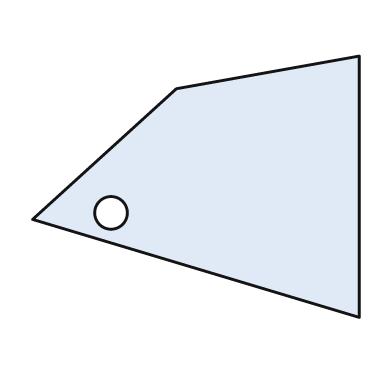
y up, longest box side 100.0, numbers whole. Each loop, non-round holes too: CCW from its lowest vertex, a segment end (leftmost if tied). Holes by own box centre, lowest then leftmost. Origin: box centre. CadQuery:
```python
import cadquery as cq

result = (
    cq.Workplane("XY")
    .moveTo(50.0, -40.0)
    .lineTo(50.0, 40.0)
    .lineTo(-6.0, 30.0)
    .lineTo(-50.0, -10.0)
    .close()
    .moveTo(-26.0, -8.0)
    .circle(5.0)
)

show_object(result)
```